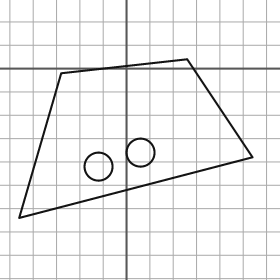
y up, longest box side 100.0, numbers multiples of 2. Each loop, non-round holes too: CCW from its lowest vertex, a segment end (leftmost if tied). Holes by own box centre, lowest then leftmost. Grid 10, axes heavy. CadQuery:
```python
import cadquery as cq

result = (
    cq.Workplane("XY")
    .moveTo(-46.0, -64.0)
    .lineTo(54.0, -38.0)
    .lineTo(26.0, 4.0)
    .lineTo(-28.0, -2.0)
    .close()
    .moveTo(-12.0, -42.0)
    .circle(6.0)
    .moveTo(6.0, -36.0)
    .circle(6.0)
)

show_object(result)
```